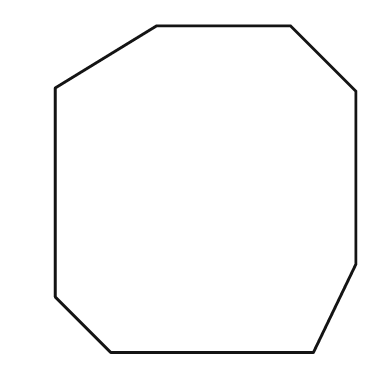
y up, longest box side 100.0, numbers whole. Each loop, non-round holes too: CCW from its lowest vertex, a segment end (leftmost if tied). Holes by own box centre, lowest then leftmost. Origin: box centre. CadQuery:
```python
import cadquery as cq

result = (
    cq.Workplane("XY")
    .moveTo(-29.0, -50.0)
    .lineTo(33.0, -50.0)
    .lineTo(46.0, -23.0)
    .lineTo(46.0, 30.0)
    .lineTo(26.0, 50.0)
    .lineTo(-15.0, 50.0)
    .lineTo(-46.0, 31.0)
    .lineTo(-46.0, -33.0)
    .close()
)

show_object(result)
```